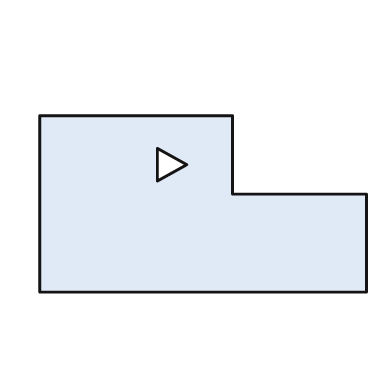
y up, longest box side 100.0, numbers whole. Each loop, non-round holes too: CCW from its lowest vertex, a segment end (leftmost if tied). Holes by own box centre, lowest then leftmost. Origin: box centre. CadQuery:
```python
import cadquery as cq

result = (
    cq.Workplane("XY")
    .moveTo(-50.0, -27.0)
    .lineTo(50.0, -27.0)
    .lineTo(50.0, 3.0)
    .lineTo(9.0, 3.0)
    .lineTo(9.0, 27.0)
    .lineTo(-50.0, 27.0)
    .close()
    .moveTo(-14.0, 7.0)
    .lineTo(-5.0, 12.0)
    .lineTo(-14.0, 17.0)
    .close()
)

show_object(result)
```